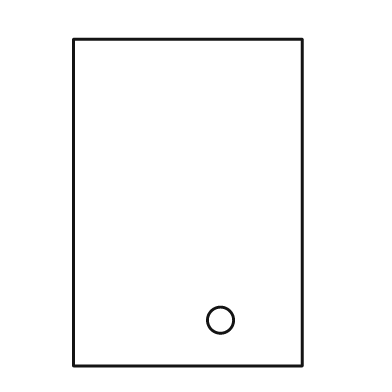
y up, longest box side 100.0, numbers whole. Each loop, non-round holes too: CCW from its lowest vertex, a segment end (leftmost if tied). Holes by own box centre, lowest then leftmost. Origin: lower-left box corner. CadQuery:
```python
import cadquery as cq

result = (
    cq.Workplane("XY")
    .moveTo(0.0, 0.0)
    .lineTo(70.0, 0.0)
    .lineTo(70.0, 100.0)
    .lineTo(0.0, 100.0)
    .close()
    .moveTo(45.0, 14.0)
    .circle(4.0)
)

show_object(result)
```